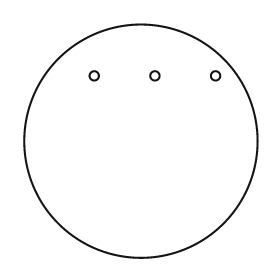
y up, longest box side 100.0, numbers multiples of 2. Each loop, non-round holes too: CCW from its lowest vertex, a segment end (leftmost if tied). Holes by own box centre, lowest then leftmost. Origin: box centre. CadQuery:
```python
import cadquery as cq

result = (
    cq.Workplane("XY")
    .moveTo(0.0, 0.0)
    .circle(50.0)
    .moveTo(-20.0, 28.0)
    .circle(2.0)
    .moveTo(6.0, 28.0)
    .circle(2.0)
    .moveTo(32.0, 28.0)
    .circle(2.0)
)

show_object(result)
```